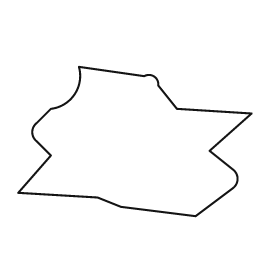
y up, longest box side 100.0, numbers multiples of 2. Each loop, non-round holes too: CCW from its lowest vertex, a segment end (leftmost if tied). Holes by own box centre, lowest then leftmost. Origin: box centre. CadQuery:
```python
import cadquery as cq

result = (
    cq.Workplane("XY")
    .moveTo(26.0, -32.0)
    .lineTo(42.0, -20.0)
    .threePointArc((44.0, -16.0), (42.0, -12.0))
    .lineTo(32.0, -4.0)
    .lineTo(50.0, 12.0)
    .lineTo(18.0, 14.0)
    .lineTo(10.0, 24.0)
    .threePointArc((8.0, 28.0), (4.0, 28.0))
    .lineTo(-24.0, 32.0)
    .threePointArc((-26.0, 20.0), (-36.0, 14.0))
    .lineTo(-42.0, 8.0)
    .threePointArc((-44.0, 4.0), (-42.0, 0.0))
    .lineTo(-36.0, -6.0)
    .lineTo(-50.0, -22.0)
    .lineTo(-16.0, -24.0)
    .lineTo(-6.0, -28.0)
    .close()
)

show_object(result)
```